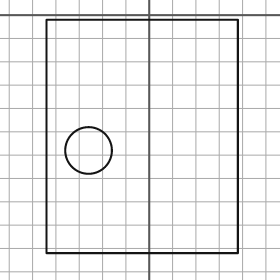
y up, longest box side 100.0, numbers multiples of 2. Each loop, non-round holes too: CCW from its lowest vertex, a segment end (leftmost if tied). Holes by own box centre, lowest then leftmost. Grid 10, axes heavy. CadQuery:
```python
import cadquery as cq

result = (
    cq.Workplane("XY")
    .moveTo(-44.0, -102.0)
    .lineTo(38.0, -102.0)
    .lineTo(38.0, -2.0)
    .lineTo(-44.0, -2.0)
    .close()
    .moveTo(-26.0, -58.0)
    .circle(10.0)
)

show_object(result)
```